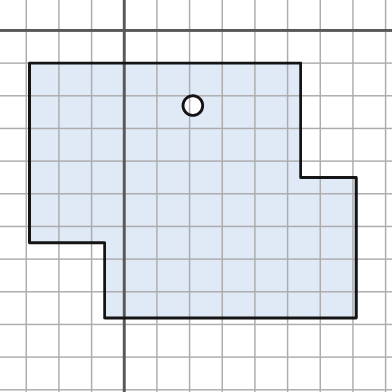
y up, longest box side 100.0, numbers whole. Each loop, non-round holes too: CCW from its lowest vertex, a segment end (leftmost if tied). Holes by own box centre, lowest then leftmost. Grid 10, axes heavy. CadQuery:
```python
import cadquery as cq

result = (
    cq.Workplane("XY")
    .moveTo(-6.0, -88.0)
    .lineTo(71.0, -88.0)
    .lineTo(71.0, -45.0)
    .lineTo(54.0, -45.0)
    .lineTo(54.0, -10.0)
    .lineTo(-29.0, -10.0)
    .lineTo(-29.0, -65.0)
    .lineTo(-6.0, -65.0)
    .close()
    .moveTo(21.0, -23.0)
    .circle(3.0)
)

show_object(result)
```